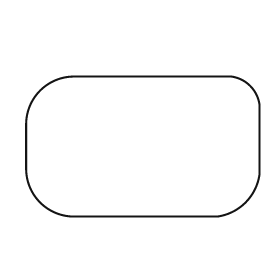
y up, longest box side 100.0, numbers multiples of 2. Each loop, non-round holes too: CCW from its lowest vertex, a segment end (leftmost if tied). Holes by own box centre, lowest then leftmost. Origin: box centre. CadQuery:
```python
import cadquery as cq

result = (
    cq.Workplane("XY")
    .moveTo(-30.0, -30.0)
    .lineTo(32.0, -30.0)
    .threePointArc((44.0, -24.0), (50.0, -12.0))
    .lineTo(50.0, 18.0)
    .threePointArc((46.0, 26.0), (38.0, 30.0))
    .lineTo(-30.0, 30.0)
    .threePointArc((-44.0, 24.0), (-50.0, 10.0))
    .lineTo(-50.0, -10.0)
    .threePointArc((-44.0, -24.0), (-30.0, -30.0))
    .close()
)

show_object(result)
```